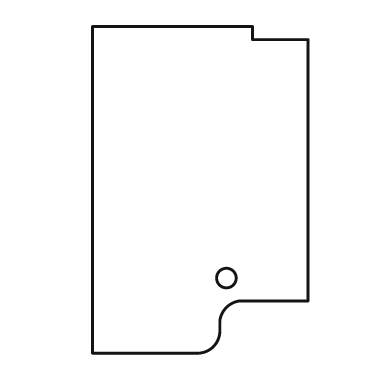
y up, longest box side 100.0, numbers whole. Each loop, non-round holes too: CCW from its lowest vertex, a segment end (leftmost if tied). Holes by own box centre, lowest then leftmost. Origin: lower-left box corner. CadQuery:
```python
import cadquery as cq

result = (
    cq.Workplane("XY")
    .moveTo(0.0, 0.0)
    .lineTo(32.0, 0.0)
    .threePointArc((37.0, 2.0), (39.0, 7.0))
    .lineTo(39.0, 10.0)
    .threePointArc((41.0, 14.0), (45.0, 16.0))
    .lineTo(66.0, 16.0)
    .lineTo(66.0, 96.0)
    .lineTo(49.0, 96.0)
    .lineTo(49.0, 100.0)
    .lineTo(0.0, 100.0)
    .close()
    .moveTo(41.0, 23.0)
    .circle(3.0)
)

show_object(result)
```